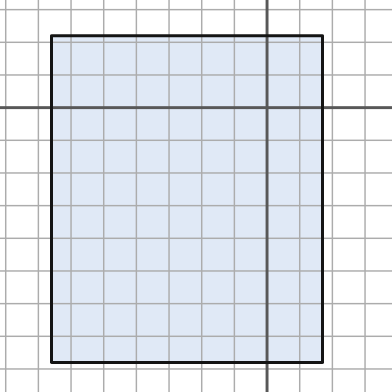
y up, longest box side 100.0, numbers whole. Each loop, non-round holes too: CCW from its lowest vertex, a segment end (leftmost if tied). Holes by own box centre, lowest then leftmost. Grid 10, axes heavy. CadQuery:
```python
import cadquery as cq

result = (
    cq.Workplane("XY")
    .moveTo(-66.0, -78.0)
    .lineTo(17.0, -78.0)
    .lineTo(17.0, 22.0)
    .lineTo(-66.0, 22.0)
    .close()
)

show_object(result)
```